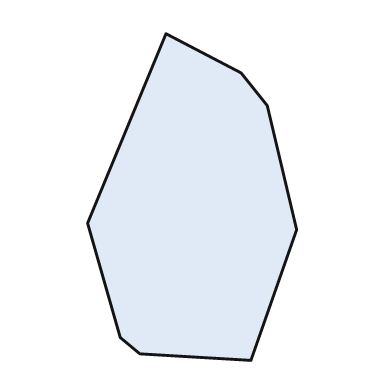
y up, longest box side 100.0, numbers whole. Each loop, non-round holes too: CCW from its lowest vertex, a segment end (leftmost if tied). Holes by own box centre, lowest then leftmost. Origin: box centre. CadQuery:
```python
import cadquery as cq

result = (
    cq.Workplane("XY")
    .moveTo(18.0, -50.0)
    .lineTo(32.0, -10.0)
    .lineTo(23.0, 28.0)
    .lineTo(15.0, 38.0)
    .lineTo(-8.0, 50.0)
    .lineTo(-32.0, -8.0)
    .lineTo(-22.0, -43.0)
    .lineTo(-16.0, -48.0)
    .close()
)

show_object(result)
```